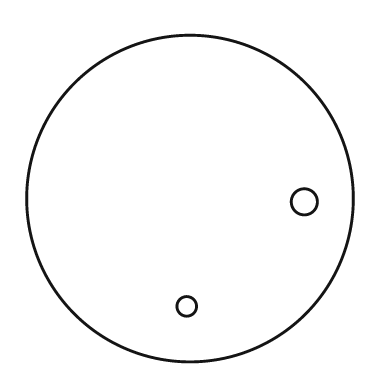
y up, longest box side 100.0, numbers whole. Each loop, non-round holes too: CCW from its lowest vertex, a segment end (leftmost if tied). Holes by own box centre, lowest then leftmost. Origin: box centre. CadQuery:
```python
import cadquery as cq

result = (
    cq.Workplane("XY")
    .moveTo(0.0, 0.0)
    .circle(50.0)
    .moveTo(-1.0, -33.0)
    .circle(3.0)
    .moveTo(35.0, -1.0)
    .circle(4.0)
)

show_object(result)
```